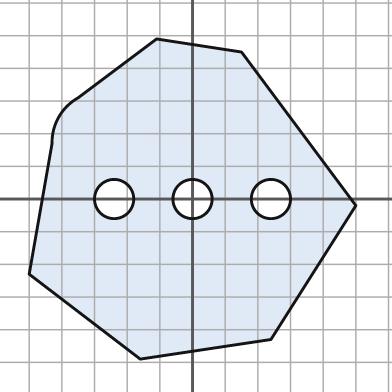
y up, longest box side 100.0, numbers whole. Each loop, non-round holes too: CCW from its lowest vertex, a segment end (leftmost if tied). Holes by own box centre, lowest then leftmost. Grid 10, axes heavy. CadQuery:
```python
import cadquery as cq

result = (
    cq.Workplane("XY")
    .moveTo(-16.0, -49.0)
    .lineTo(24.0, -43.0)
    .lineTo(50.0, -2.0)
    .lineTo(15.0, 45.0)
    .lineTo(-11.0, 49.0)
    .lineTo(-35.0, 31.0)
    .threePointArc((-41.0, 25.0), (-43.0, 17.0))
    .lineTo(-50.0, -23.0)
    .close()
    .moveTo(-24.0, 0.0)
    .circle(6.0)
    .moveTo(0.0, 0.0)
    .circle(6.0)
    .moveTo(24.0, 0.0)
    .circle(6.0)
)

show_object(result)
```